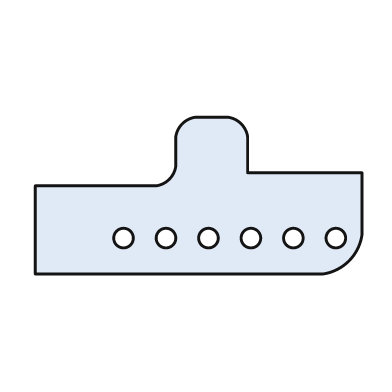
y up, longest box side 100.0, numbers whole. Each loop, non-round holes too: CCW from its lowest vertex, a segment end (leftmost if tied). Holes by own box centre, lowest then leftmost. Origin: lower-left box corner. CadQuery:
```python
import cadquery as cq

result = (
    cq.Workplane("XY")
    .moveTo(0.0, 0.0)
    .lineTo(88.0, 0.0)
    .threePointArc((96.0, 4.0), (100.0, 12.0))
    .lineTo(100.0, 31.0)
    .lineTo(65.0, 31.0)
    .lineTo(65.0, 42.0)
    .threePointArc((63.0, 46.0), (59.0, 48.0))
    .lineTo(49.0, 48.0)
    .threePointArc((45.0, 46.0), (43.0, 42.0))
    .lineTo(43.0, 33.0)
    .threePointArc((41.0, 29.0), (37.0, 27.0))
    .lineTo(0.0, 27.0)
    .close()
    .moveTo(27.0, 11.0)
    .circle(3.0)
    .moveTo(40.0, 11.0)
    .circle(3.0)
    .moveTo(53.0, 11.0)
    .circle(3.0)
    .moveTo(66.0, 11.0)
    .circle(3.0)
    .moveTo(79.0, 11.0)
    .circle(3.0)
    .moveTo(92.0, 11.0)
    .circle(3.0)
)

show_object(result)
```